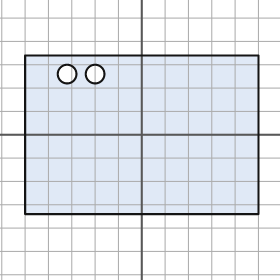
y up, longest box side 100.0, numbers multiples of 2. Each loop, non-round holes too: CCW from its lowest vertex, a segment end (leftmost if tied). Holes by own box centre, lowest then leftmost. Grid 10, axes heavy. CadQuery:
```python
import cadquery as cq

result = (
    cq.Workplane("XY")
    .moveTo(-50.0, -34.0)
    .lineTo(50.0, -34.0)
    .lineTo(50.0, 34.0)
    .lineTo(-50.0, 34.0)
    .close()
    .moveTo(-32.0, 26.0)
    .circle(4.0)
    .moveTo(-20.0, 26.0)
    .circle(4.0)
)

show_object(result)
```